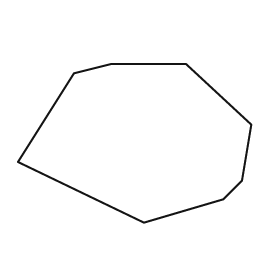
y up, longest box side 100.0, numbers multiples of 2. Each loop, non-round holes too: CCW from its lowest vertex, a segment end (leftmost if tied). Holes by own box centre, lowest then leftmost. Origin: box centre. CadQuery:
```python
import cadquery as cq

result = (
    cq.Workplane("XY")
    .moveTo(4.0, -34.0)
    .lineTo(38.0, -24.0)
    .lineTo(46.0, -16.0)
    .lineTo(50.0, 8.0)
    .lineTo(22.0, 34.0)
    .lineTo(-10.0, 34.0)
    .lineTo(-26.0, 30.0)
    .lineTo(-50.0, -8.0)
    .close()
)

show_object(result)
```